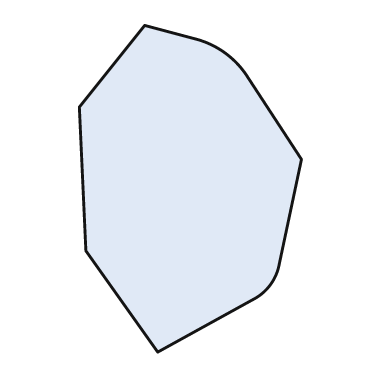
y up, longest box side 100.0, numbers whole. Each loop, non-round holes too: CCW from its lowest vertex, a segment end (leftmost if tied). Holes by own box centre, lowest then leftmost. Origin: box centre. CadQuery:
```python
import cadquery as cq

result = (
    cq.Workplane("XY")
    .moveTo(-10.0, -50.0)
    .lineTo(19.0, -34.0)
    .threePointArc((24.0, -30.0), (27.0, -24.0))
    .lineTo(34.0, 9.0)
    .lineTo(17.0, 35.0)
    .threePointArc((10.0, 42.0), (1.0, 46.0))
    .lineTo(-14.0, 50.0)
    .lineTo(-34.0, 25.0)
    .lineTo(-32.0, -19.0)
    .close()
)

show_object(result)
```